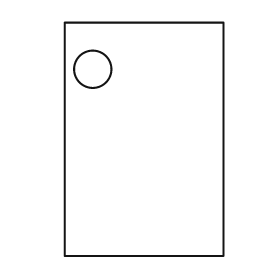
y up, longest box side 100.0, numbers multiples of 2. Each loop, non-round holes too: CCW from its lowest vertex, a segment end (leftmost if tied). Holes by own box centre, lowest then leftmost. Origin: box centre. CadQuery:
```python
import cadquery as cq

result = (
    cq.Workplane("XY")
    .moveTo(-34.0, -50.0)
    .lineTo(34.0, -50.0)
    .lineTo(34.0, 50.0)
    .lineTo(-34.0, 50.0)
    .close()
    .moveTo(-22.0, 30.0)
    .circle(8.0)
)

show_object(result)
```